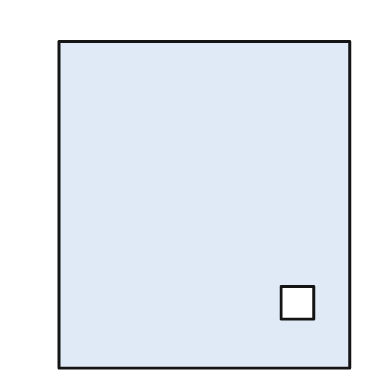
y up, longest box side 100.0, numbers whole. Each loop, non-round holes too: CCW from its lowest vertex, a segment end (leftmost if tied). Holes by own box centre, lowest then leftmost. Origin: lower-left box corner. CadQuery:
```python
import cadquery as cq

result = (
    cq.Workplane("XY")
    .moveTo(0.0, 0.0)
    .lineTo(89.0, 0.0)
    .lineTo(89.0, 100.0)
    .lineTo(0.0, 100.0)
    .close()
    .moveTo(68.0, 15.0)
    .lineTo(78.0, 15.0)
    .lineTo(78.0, 25.0)
    .lineTo(68.0, 25.0)
    .close()
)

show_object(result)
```